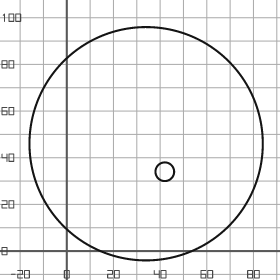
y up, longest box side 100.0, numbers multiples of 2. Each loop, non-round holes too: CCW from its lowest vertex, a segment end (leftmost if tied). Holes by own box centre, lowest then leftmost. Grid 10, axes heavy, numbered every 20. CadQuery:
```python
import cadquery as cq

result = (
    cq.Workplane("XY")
    .moveTo(34.0, 46.0)
    .circle(50.0)
    .moveTo(42.0, 34.0)
    .circle(4.0)
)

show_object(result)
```